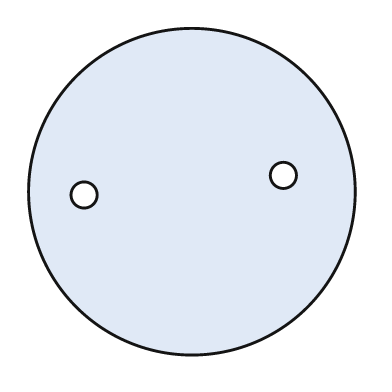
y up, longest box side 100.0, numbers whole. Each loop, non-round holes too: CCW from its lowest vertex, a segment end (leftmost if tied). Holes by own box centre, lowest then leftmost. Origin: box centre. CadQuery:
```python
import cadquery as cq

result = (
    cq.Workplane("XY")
    .moveTo(0.0, 0.0)
    .circle(50.0)
    .moveTo(-33.0, -1.0)
    .circle(4.0)
    .moveTo(28.0, 5.0)
    .circle(4.0)
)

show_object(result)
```